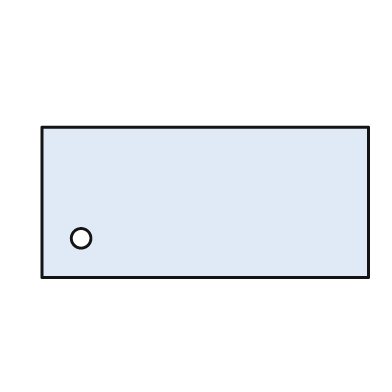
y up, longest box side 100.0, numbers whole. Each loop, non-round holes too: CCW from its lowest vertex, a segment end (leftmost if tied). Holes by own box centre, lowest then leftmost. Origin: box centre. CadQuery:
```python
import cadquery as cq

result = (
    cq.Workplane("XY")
    .moveTo(-50.0, -23.0)
    .lineTo(50.0, -23.0)
    .lineTo(50.0, 23.0)
    .lineTo(-50.0, 23.0)
    .close()
    .moveTo(-38.0, -11.0)
    .circle(3.0)
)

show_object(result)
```